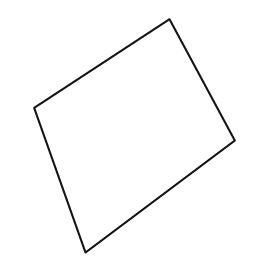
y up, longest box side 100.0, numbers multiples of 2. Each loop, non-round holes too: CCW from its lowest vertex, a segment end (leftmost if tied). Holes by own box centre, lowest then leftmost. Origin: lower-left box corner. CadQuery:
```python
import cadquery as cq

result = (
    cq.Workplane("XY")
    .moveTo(22.0, 0.0)
    .lineTo(86.0, 48.0)
    .lineTo(58.0, 100.0)
    .lineTo(0.0, 62.0)
    .close()
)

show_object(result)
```